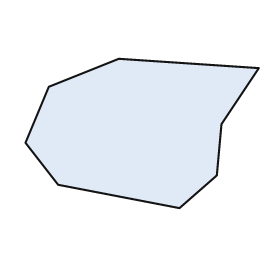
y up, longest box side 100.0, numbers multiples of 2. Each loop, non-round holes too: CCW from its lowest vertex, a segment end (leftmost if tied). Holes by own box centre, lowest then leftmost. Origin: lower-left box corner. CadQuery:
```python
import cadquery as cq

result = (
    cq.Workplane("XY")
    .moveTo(66.0, 0.0)
    .lineTo(82.0, 14.0)
    .lineTo(84.0, 36.0)
    .lineTo(100.0, 60.0)
    .lineTo(40.0, 64.0)
    .lineTo(10.0, 52.0)
    .lineTo(0.0, 28.0)
    .lineTo(14.0, 10.0)
    .close()
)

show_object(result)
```